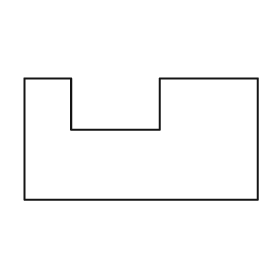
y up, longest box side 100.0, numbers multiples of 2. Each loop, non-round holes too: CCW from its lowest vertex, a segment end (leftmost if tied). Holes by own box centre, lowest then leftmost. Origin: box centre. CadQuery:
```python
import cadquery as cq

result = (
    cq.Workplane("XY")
    .moveTo(-50.0, -26.0)
    .lineTo(50.0, -26.0)
    .lineTo(50.0, 26.0)
    .lineTo(8.0, 26.0)
    .lineTo(8.0, 4.0)
    .lineTo(-30.0, 4.0)
    .lineTo(-30.0, 26.0)
    .lineTo(-50.0, 26.0)
    .close()
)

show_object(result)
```